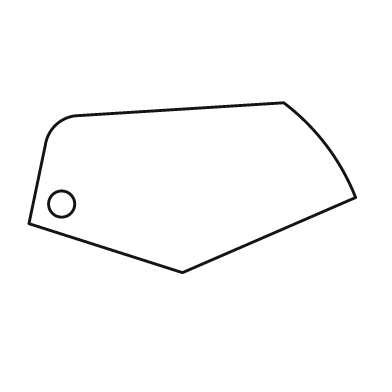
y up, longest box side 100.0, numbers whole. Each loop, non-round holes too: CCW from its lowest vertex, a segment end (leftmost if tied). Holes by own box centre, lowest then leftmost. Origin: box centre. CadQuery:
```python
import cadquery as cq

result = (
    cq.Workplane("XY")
    .moveTo(-3.0, -26.0)
    .lineTo(50.0, -3.0)
    .threePointArc((41.0, 13.0), (28.0, 26.0))
    .lineTo(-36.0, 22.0)
    .threePointArc((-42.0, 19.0), (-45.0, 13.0))
    .lineTo(-50.0, -11.0)
    .close()
    .moveTo(-40.0, -5.0)
    .circle(4.0)
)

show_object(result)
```